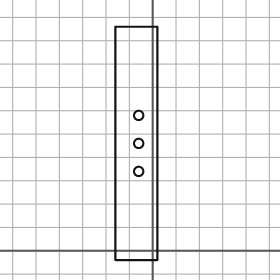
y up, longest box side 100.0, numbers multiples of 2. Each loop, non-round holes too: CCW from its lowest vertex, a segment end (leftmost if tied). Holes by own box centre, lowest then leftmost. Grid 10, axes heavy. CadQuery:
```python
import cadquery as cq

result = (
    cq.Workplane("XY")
    .moveTo(-16.0, -4.0)
    .lineTo(2.0, -4.0)
    .lineTo(2.0, 96.0)
    .lineTo(-16.0, 96.0)
    .close()
    .moveTo(-6.0, 34.0)
    .circle(2.0)
    .moveTo(-6.0, 46.0)
    .circle(2.0)
    .moveTo(-6.0, 58.0)
    .circle(2.0)
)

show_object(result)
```